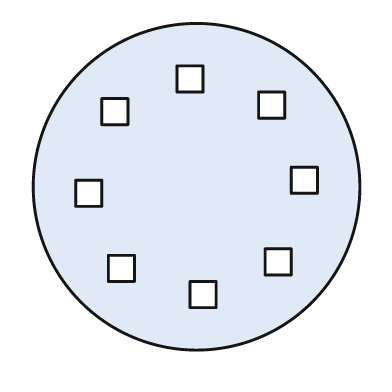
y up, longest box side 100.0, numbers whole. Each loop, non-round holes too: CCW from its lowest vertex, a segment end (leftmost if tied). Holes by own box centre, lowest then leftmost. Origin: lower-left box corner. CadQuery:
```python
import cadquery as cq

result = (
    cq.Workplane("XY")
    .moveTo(50.0, 50.0)
    .circle(50.0)
    .moveTo(48.0, 13.0)
    .lineTo(56.0, 13.0)
    .lineTo(56.0, 21.0)
    .lineTo(48.0, 21.0)
    .close()
    .moveTo(23.0, 21.0)
    .lineTo(31.0, 21.0)
    .lineTo(31.0, 29.0)
    .lineTo(23.0, 29.0)
    .close()
    .moveTo(71.0, 23.0)
    .lineTo(79.0, 23.0)
    .lineTo(79.0, 31.0)
    .lineTo(71.0, 31.0)
    .close()
    .moveTo(13.0, 44.0)
    .lineTo(21.0, 44.0)
    .lineTo(21.0, 52.0)
    .lineTo(13.0, 52.0)
    .close()
    .moveTo(79.0, 48.0)
    .lineTo(87.0, 48.0)
    .lineTo(87.0, 56.0)
    .lineTo(79.0, 56.0)
    .close()
    .moveTo(21.0, 69.0)
    .lineTo(29.0, 69.0)
    .lineTo(29.0, 77.0)
    .lineTo(21.0, 77.0)
    .close()
    .moveTo(69.0, 71.0)
    .lineTo(77.0, 71.0)
    .lineTo(77.0, 79.0)
    .lineTo(69.0, 79.0)
    .close()
    .moveTo(44.0, 79.0)
    .lineTo(52.0, 79.0)
    .lineTo(52.0, 87.0)
    .lineTo(44.0, 87.0)
    .close()
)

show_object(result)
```